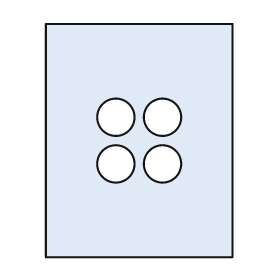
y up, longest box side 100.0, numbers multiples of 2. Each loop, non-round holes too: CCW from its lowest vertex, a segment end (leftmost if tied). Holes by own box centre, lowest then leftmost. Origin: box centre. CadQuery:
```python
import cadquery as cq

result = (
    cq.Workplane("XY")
    .moveTo(-40.0, -50.0)
    .lineTo(40.0, -50.0)
    .lineTo(40.0, 50.0)
    .lineTo(-40.0, 50.0)
    .close()
    .moveTo(-10.0, -10.0)
    .circle(8.0)
    .moveTo(10.0, -10.0)
    .circle(8.0)
    .moveTo(-10.0, 10.0)
    .circle(8.0)
    .moveTo(10.0, 10.0)
    .circle(8.0)
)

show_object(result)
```